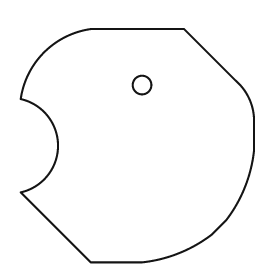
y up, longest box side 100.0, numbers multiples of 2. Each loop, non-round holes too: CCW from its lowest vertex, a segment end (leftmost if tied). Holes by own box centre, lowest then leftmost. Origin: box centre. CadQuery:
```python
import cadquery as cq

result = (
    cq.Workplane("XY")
    .moveTo(-20.0, -50.0)
    .lineTo(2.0, -50.0)
    .threePointArc((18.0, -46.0), (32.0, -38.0))
    .lineTo(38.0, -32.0)
    .threePointArc((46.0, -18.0), (50.0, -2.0))
    .lineTo(50.0, 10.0)
    .threePointArc((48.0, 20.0), (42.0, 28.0))
    .lineTo(20.0, 50.0)
    .lineTo(-20.0, 50.0)
    .threePointArc((-40.0, 40.0), (-50.0, 20.0))
    .threePointArc((-34.0, 0.0), (-50.0, -20.0))
    .close()
    .moveTo(2.0, 26.0)
    .circle(4.0)
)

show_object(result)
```